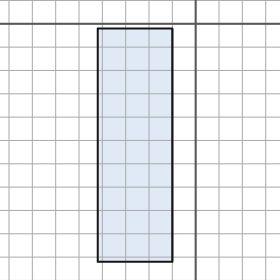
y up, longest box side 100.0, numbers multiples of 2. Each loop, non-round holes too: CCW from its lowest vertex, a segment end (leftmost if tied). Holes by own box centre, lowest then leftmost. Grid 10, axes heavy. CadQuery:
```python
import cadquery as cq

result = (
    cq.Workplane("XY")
    .moveTo(-42.0, -102.0)
    .lineTo(-10.0, -102.0)
    .lineTo(-10.0, -2.0)
    .lineTo(-42.0, -2.0)
    .close()
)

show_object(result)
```